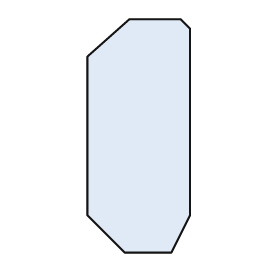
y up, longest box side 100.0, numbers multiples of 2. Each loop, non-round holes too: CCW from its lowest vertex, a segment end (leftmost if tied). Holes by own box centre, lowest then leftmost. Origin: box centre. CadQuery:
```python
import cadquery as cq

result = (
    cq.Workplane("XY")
    .moveTo(-6.0, -50.0)
    .lineTo(14.0, -50.0)
    .lineTo(22.0, -34.0)
    .lineTo(22.0, 46.0)
    .lineTo(18.0, 50.0)
    .lineTo(-4.0, 50.0)
    .lineTo(-22.0, 34.0)
    .lineTo(-22.0, -34.0)
    .close()
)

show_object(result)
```